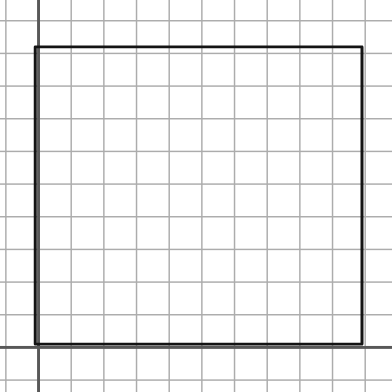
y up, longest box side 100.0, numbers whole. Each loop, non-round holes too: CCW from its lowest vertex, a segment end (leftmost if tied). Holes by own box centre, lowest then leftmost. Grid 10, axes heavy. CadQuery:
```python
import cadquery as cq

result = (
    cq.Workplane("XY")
    .moveTo(-1.0, 1.0)
    .lineTo(99.0, 1.0)
    .lineTo(99.0, 92.0)
    .lineTo(-1.0, 92.0)
    .close()
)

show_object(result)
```